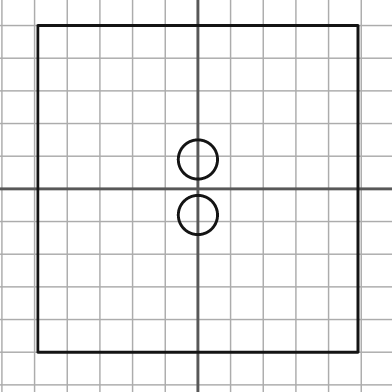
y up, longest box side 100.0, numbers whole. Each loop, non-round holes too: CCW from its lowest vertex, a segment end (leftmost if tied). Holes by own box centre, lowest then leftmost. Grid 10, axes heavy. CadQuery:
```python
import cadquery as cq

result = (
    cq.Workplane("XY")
    .moveTo(-49.0, -50.0)
    .lineTo(49.0, -50.0)
    .lineTo(49.0, 50.0)
    .lineTo(-49.0, 50.0)
    .close()
    .moveTo(0.0, -8.0)
    .circle(6.0)
    .moveTo(0.0, 9.0)
    .circle(6.0)
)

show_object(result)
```